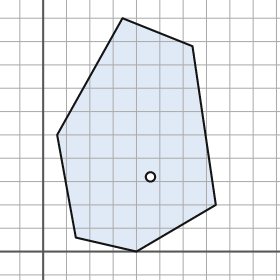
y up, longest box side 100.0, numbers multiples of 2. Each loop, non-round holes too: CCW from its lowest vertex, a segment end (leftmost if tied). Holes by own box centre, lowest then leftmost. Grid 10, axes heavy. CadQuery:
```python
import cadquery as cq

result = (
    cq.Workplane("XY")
    .moveTo(40.0, 0.0)
    .lineTo(74.0, 20.0)
    .lineTo(64.0, 88.0)
    .lineTo(34.0, 100.0)
    .lineTo(6.0, 50.0)
    .lineTo(14.0, 6.0)
    .close()
    .moveTo(46.0, 32.0)
    .circle(2.0)
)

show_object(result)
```